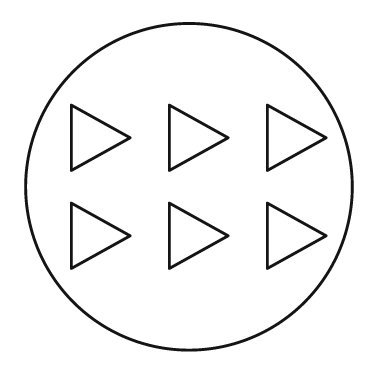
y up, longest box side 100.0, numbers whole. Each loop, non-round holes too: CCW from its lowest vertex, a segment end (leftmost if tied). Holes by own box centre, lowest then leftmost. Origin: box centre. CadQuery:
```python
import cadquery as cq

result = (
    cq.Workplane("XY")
    .moveTo(0.0, 0.0)
    .circle(50.0)
    .moveTo(-36.0, -25.0)
    .lineTo(-18.0, -15.0)
    .lineTo(-36.0, -5.0)
    .close()
    .moveTo(-6.0, -25.0)
    .lineTo(12.0, -15.0)
    .lineTo(-6.0, -5.0)
    .close()
    .moveTo(24.0, -25.0)
    .lineTo(42.0, -15.0)
    .lineTo(24.0, -5.0)
    .close()
    .moveTo(-36.0, 5.0)
    .lineTo(-18.0, 15.0)
    .lineTo(-36.0, 25.0)
    .close()
    .moveTo(-6.0, 5.0)
    .lineTo(12.0, 15.0)
    .lineTo(-6.0, 25.0)
    .close()
    .moveTo(24.0, 5.0)
    .lineTo(42.0, 15.0)
    .lineTo(24.0, 25.0)
    .close()
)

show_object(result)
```